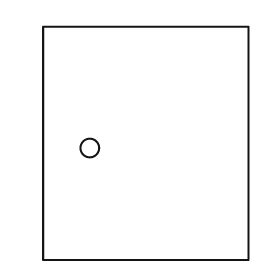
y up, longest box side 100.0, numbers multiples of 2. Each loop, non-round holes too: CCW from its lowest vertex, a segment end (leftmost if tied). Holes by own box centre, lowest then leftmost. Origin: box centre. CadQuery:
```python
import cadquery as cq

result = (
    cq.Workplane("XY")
    .moveTo(-44.0, -50.0)
    .lineTo(44.0, -50.0)
    .lineTo(44.0, 50.0)
    .lineTo(-44.0, 50.0)
    .close()
    .moveTo(-24.0, -2.0)
    .circle(4.0)
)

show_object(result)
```